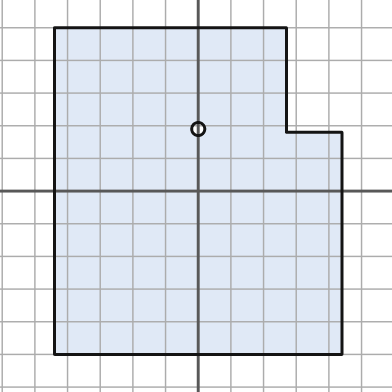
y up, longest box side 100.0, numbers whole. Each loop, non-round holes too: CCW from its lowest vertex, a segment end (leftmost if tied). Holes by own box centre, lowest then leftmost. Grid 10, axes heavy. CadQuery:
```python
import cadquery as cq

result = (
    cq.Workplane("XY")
    .moveTo(-44.0, -50.0)
    .lineTo(44.0, -50.0)
    .lineTo(44.0, 18.0)
    .lineTo(27.0, 18.0)
    .lineTo(27.0, 50.0)
    .lineTo(-44.0, 50.0)
    .close()
    .moveTo(0.0, 19.0)
    .circle(2.0)
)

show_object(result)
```